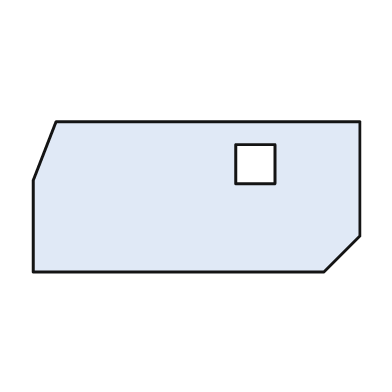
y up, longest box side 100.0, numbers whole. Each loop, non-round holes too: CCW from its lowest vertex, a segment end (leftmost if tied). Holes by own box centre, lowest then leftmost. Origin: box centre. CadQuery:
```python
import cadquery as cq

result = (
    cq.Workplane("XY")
    .moveTo(-50.0, -23.0)
    .lineTo(39.0, -23.0)
    .lineTo(50.0, -12.0)
    .lineTo(50.0, 23.0)
    .lineTo(-43.0, 23.0)
    .lineTo(-50.0, 5.0)
    .close()
    .moveTo(12.0, 4.0)
    .lineTo(24.0, 4.0)
    .lineTo(24.0, 16.0)
    .lineTo(12.0, 16.0)
    .close()
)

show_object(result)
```